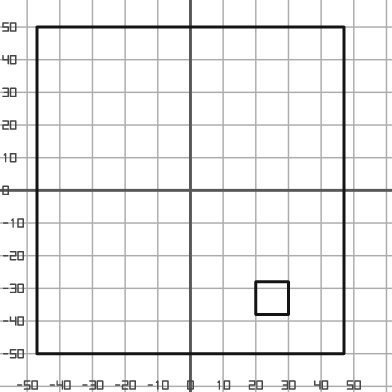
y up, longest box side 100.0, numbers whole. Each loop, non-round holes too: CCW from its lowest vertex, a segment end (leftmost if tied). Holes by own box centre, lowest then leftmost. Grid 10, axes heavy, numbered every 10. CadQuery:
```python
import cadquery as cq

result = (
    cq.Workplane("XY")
    .moveTo(-47.0, -50.0)
    .lineTo(47.0, -50.0)
    .lineTo(47.0, 50.0)
    .lineTo(-47.0, 50.0)
    .close()
    .moveTo(20.0, -38.0)
    .lineTo(30.0, -38.0)
    .lineTo(30.0, -28.0)
    .lineTo(20.0, -28.0)
    .close()
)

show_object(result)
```